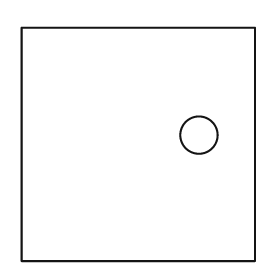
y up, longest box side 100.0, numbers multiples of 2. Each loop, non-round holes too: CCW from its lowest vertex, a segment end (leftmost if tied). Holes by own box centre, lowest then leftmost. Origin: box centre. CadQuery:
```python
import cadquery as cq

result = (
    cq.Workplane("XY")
    .moveTo(-50.0, -50.0)
    .lineTo(50.0, -50.0)
    .lineTo(50.0, 50.0)
    .lineTo(-50.0, 50.0)
    .close()
    .moveTo(26.0, 4.0)
    .circle(8.0)
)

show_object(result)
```